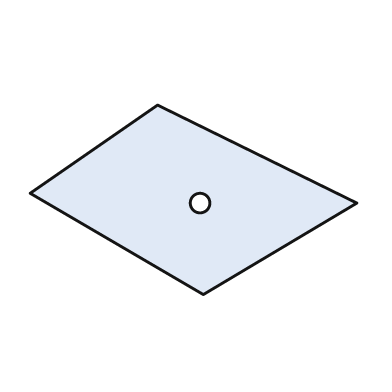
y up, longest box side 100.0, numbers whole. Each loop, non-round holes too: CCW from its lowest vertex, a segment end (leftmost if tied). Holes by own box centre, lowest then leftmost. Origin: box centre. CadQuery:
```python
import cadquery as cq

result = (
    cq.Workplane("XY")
    .moveTo(3.0, -29.0)
    .lineTo(50.0, -1.0)
    .lineTo(-11.0, 29.0)
    .lineTo(-50.0, 2.0)
    .close()
    .moveTo(2.0, -1.0)
    .circle(3.0)
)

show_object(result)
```